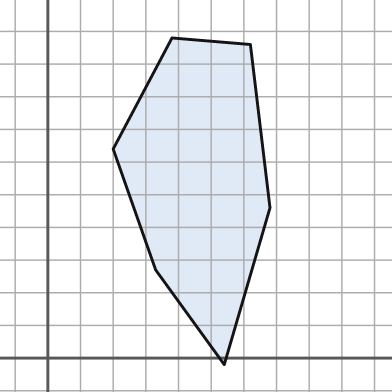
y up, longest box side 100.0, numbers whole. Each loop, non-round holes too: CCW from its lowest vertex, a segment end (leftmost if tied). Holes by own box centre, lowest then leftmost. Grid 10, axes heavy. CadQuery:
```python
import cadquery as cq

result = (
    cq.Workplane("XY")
    .moveTo(54.0, -2.0)
    .lineTo(68.0, 46.0)
    .lineTo(62.0, 96.0)
    .lineTo(38.0, 98.0)
    .lineTo(20.0, 64.0)
    .lineTo(33.0, 27.0)
    .close()
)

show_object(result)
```